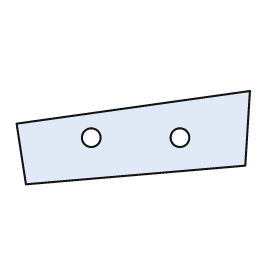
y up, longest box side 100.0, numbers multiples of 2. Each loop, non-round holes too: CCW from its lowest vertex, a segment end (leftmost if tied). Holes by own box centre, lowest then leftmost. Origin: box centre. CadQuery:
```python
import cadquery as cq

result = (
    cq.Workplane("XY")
    .moveTo(-46.0, -20.0)
    .lineTo(48.0, -12.0)
    .lineTo(50.0, 20.0)
    .lineTo(-50.0, 6.0)
    .close()
    .moveTo(-18.0, 0.0)
    .circle(4.0)
    .moveTo(20.0, 0.0)
    .circle(4.0)
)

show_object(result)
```